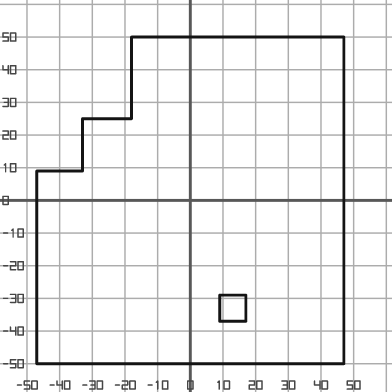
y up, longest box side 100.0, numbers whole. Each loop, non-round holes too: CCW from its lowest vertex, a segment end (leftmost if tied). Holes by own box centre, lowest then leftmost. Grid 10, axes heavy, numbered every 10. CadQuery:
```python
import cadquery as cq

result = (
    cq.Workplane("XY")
    .moveTo(-47.0, -50.0)
    .lineTo(47.0, -50.0)
    .lineTo(47.0, 50.0)
    .lineTo(-18.0, 50.0)
    .lineTo(-18.0, 25.0)
    .lineTo(-33.0, 25.0)
    .lineTo(-33.0, 9.0)
    .lineTo(-47.0, 9.0)
    .close()
    .moveTo(9.0, -37.0)
    .lineTo(17.0, -37.0)
    .lineTo(17.0, -29.0)
    .lineTo(9.0, -29.0)
    .close()
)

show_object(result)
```